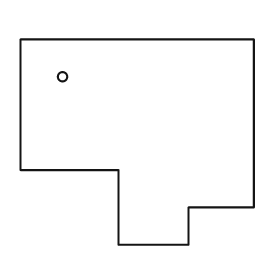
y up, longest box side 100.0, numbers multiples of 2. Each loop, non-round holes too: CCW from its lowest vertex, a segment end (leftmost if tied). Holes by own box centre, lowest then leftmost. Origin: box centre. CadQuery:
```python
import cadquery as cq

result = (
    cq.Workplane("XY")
    .moveTo(-8.0, -44.0)
    .lineTo(22.0, -44.0)
    .lineTo(22.0, -28.0)
    .lineTo(50.0, -28.0)
    .lineTo(50.0, 44.0)
    .lineTo(-50.0, 44.0)
    .lineTo(-50.0, -12.0)
    .lineTo(-8.0, -12.0)
    .close()
    .moveTo(-32.0, 28.0)
    .circle(2.0)
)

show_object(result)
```